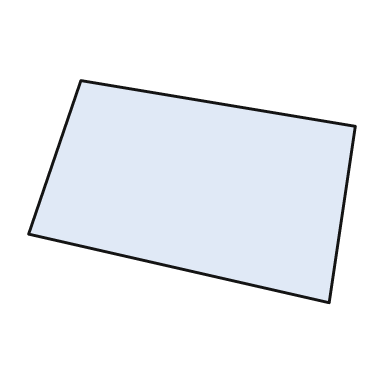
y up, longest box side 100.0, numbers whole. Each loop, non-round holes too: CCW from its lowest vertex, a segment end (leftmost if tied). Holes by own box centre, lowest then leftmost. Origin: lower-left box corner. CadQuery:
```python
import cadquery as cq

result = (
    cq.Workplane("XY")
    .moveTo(92.0, 0.0)
    .lineTo(100.0, 54.0)
    .lineTo(16.0, 68.0)
    .lineTo(0.0, 21.0)
    .close()
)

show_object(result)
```